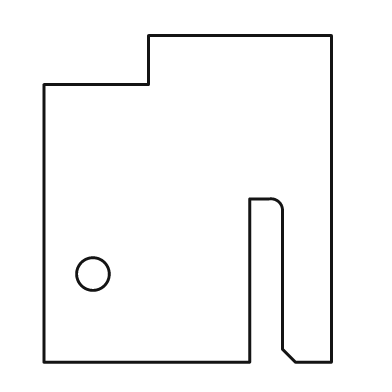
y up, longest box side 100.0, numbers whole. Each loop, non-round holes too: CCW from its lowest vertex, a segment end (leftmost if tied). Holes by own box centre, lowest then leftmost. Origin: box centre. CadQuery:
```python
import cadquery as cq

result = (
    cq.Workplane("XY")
    .moveTo(-44.0, -50.0)
    .lineTo(19.0, -50.0)
    .lineTo(19.0, 0.0)
    .lineTo(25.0, 0.0)
    .threePointArc((28.0, -1.0), (29.0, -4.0))
    .lineTo(29.0, -46.0)
    .lineTo(33.0, -50.0)
    .lineTo(44.0, -50.0)
    .lineTo(44.0, 50.0)
    .lineTo(-12.0, 50.0)
    .lineTo(-12.0, 35.0)
    .lineTo(-44.0, 35.0)
    .close()
    .moveTo(-29.0, -23.0)
    .circle(5.0)
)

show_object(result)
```